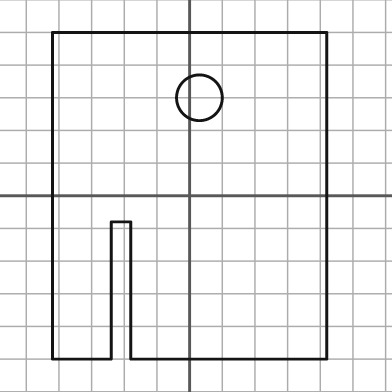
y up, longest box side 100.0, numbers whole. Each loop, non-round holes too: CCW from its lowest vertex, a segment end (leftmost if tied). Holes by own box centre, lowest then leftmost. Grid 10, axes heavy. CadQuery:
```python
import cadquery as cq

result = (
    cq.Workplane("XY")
    .moveTo(-42.0, -50.0)
    .lineTo(-24.0, -50.0)
    .lineTo(-24.0, -8.0)
    .lineTo(-18.0, -8.0)
    .lineTo(-18.0, -50.0)
    .lineTo(42.0, -50.0)
    .lineTo(42.0, 50.0)
    .lineTo(-42.0, 50.0)
    .close()
    .moveTo(3.0, 30.0)
    .circle(7.0)
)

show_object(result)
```